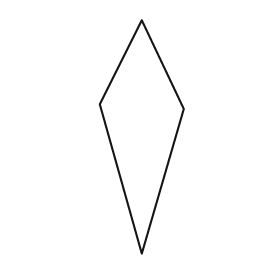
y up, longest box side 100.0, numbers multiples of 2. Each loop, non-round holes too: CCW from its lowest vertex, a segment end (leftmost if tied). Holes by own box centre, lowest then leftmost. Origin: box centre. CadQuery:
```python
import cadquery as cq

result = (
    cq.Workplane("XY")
    .moveTo(0.0, -50.0)
    .lineTo(18.0, 12.0)
    .lineTo(0.0, 50.0)
    .lineTo(-18.0, 14.0)
    .close()
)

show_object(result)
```